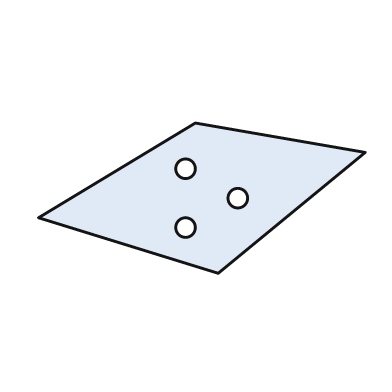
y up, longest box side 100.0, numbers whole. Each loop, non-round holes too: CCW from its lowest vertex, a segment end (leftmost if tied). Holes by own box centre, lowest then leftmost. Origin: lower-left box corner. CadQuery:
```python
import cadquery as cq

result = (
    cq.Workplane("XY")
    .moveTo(55.0, 0.0)
    .lineTo(100.0, 37.0)
    .lineTo(48.0, 46.0)
    .lineTo(0.0, 17.0)
    .close()
    .moveTo(45.0, 14.0)
    .circle(3.0)
    .moveTo(61.0, 23.0)
    .circle(3.0)
    .moveTo(45.0, 32.0)
    .circle(3.0)
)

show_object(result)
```